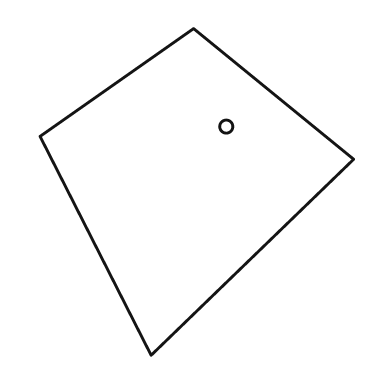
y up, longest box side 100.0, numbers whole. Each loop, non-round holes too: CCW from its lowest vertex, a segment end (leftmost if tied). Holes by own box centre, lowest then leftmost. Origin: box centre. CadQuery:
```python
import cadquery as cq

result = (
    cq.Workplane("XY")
    .moveTo(-14.0, -50.0)
    .lineTo(48.0, 10.0)
    .lineTo(-1.0, 50.0)
    .lineTo(-48.0, 17.0)
    .close()
    .moveTo(9.0, 20.0)
    .circle(2.0)
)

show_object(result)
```